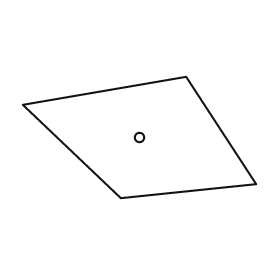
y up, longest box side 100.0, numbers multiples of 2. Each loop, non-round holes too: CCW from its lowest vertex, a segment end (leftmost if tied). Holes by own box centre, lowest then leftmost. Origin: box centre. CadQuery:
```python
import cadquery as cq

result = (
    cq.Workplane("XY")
    .moveTo(-8.0, -26.0)
    .lineTo(50.0, -20.0)
    .lineTo(20.0, 26.0)
    .lineTo(-50.0, 14.0)
    .close()
    .moveTo(0.0, 0.0)
    .circle(2.0)
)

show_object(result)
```